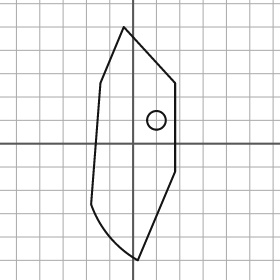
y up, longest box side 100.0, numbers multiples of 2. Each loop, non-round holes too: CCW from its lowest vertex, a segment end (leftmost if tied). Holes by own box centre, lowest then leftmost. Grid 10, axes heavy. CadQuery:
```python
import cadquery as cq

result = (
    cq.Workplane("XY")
    .moveTo(2.0, -50.0)
    .lineTo(18.0, -12.0)
    .lineTo(18.0, 26.0)
    .lineTo(-4.0, 50.0)
    .lineTo(-14.0, 26.0)
    .lineTo(-18.0, -26.0)
    .threePointArc((-10.0, -40.0), (2.0, -50.0))
    .close()
    .moveTo(10.0, 10.0)
    .circle(4.0)
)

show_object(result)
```